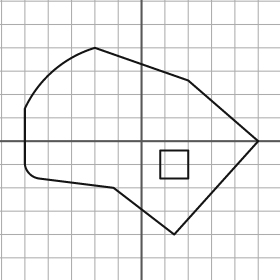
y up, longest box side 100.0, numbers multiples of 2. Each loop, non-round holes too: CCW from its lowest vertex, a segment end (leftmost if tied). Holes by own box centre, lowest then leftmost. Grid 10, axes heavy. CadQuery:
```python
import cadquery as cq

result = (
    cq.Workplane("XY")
    .moveTo(14.0, -40.0)
    .lineTo(50.0, 0.0)
    .lineTo(20.0, 26.0)
    .lineTo(-20.0, 40.0)
    .threePointArc((-38.0, 30.0), (-50.0, 14.0))
    .lineTo(-50.0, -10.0)
    .threePointArc((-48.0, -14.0), (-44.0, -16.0))
    .lineTo(-12.0, -20.0)
    .close()
    .moveTo(8.0, -16.0)
    .lineTo(20.0, -16.0)
    .lineTo(20.0, -4.0)
    .lineTo(8.0, -4.0)
    .close()
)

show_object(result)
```